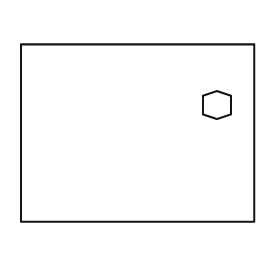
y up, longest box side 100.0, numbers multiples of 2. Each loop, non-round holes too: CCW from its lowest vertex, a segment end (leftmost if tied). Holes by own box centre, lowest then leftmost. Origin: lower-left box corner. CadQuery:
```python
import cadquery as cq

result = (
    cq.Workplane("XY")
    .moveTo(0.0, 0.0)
    .lineTo(100.0, 0.0)
    .lineTo(100.0, 76.0)
    .lineTo(0.0, 76.0)
    .close()
    .moveTo(84.0, 44.0)
    .lineTo(90.0, 46.0)
    .lineTo(90.0, 54.0)
    .lineTo(84.0, 56.0)
    .lineTo(78.0, 54.0)
    .lineTo(78.0, 46.0)
    .close()
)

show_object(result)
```